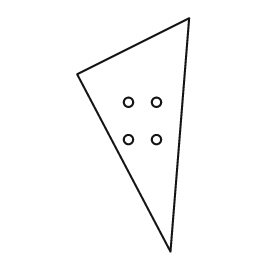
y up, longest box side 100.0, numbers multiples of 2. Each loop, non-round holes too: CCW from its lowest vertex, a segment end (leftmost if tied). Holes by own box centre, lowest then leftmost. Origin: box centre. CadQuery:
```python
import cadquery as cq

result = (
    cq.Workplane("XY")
    .moveTo(16.0, -50.0)
    .lineTo(24.0, 50.0)
    .lineTo(-24.0, 26.0)
    .close()
    .moveTo(-2.0, -2.0)
    .circle(2.0)
    .moveTo(10.0, -2.0)
    .circle(2.0)
    .moveTo(-2.0, 14.0)
    .circle(2.0)
    .moveTo(10.0, 14.0)
    .circle(2.0)
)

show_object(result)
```